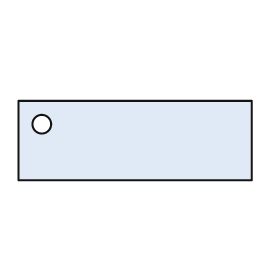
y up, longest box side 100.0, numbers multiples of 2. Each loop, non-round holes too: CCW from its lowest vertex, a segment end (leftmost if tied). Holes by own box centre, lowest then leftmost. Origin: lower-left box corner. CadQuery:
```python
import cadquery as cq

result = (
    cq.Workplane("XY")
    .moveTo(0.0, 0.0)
    .lineTo(100.0, 0.0)
    .lineTo(100.0, 34.0)
    .lineTo(0.0, 34.0)
    .close()
    .moveTo(10.0, 24.0)
    .circle(4.0)
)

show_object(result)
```